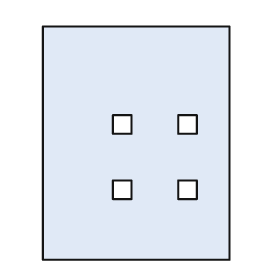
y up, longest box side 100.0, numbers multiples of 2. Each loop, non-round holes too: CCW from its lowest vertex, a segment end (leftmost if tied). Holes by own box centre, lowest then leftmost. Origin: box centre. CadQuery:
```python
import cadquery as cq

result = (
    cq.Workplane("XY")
    .moveTo(-40.0, -50.0)
    .lineTo(40.0, -50.0)
    .lineTo(40.0, 50.0)
    .lineTo(-40.0, 50.0)
    .close()
    .moveTo(-10.0, -24.0)
    .lineTo(-2.0, -24.0)
    .lineTo(-2.0, -16.0)
    .lineTo(-10.0, -16.0)
    .close()
    .moveTo(18.0, -24.0)
    .lineTo(26.0, -24.0)
    .lineTo(26.0, -16.0)
    .lineTo(18.0, -16.0)
    .close()
    .moveTo(-10.0, 4.0)
    .lineTo(-2.0, 4.0)
    .lineTo(-2.0, 12.0)
    .lineTo(-10.0, 12.0)
    .close()
    .moveTo(18.0, 4.0)
    .lineTo(26.0, 4.0)
    .lineTo(26.0, 12.0)
    .lineTo(18.0, 12.0)
    .close()
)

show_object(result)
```